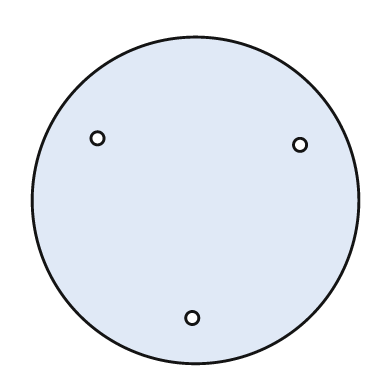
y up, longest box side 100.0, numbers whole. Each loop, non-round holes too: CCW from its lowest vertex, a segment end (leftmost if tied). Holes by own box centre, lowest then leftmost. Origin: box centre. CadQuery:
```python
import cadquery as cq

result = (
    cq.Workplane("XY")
    .moveTo(0.0, 0.0)
    .circle(50.0)
    .moveTo(-1.0, -36.0)
    .circle(2.0)
    .moveTo(32.0, 17.0)
    .circle(2.0)
    .moveTo(-30.0, 19.0)
    .circle(2.0)
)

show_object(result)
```